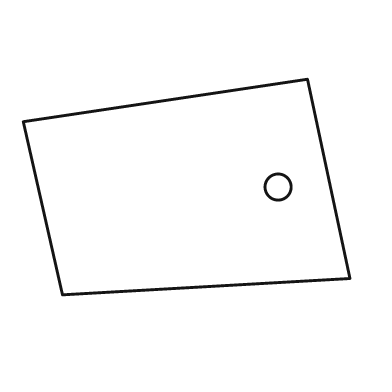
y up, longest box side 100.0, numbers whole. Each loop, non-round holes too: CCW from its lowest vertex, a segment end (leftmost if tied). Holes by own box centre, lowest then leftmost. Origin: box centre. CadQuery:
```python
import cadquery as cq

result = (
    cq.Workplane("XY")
    .moveTo(-38.0, -33.0)
    .lineTo(50.0, -28.0)
    .lineTo(37.0, 33.0)
    .lineTo(-50.0, 20.0)
    .close()
    .moveTo(28.0, 0.0)
    .circle(4.0)
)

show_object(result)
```